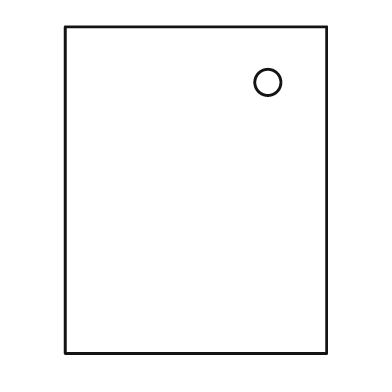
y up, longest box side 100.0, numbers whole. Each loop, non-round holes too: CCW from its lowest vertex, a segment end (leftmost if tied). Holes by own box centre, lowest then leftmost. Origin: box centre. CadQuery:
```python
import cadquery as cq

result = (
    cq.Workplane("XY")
    .moveTo(-40.0, -50.0)
    .lineTo(40.0, -50.0)
    .lineTo(40.0, 50.0)
    .lineTo(-40.0, 50.0)
    .close()
    .moveTo(22.0, 33.0)
    .circle(4.0)
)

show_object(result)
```